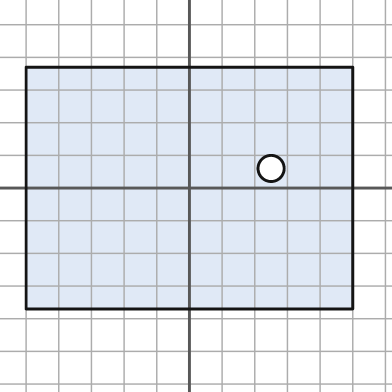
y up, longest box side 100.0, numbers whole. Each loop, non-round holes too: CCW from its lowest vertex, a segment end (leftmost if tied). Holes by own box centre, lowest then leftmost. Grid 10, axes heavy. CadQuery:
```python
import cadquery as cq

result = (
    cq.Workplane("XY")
    .moveTo(-50.0, -37.0)
    .lineTo(50.0, -37.0)
    .lineTo(50.0, 37.0)
    .lineTo(-50.0, 37.0)
    .close()
    .moveTo(25.0, 6.0)
    .circle(4.0)
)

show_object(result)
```